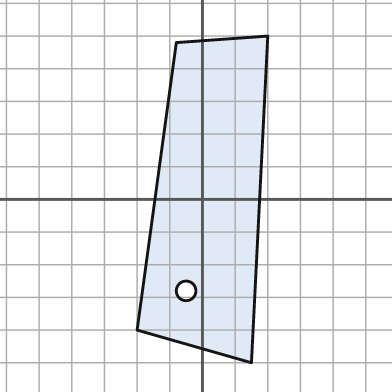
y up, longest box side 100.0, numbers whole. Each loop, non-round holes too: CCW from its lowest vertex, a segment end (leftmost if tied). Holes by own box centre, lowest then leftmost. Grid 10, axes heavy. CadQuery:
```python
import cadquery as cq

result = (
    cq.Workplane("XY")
    .moveTo(15.0, -50.0)
    .lineTo(20.0, 50.0)
    .lineTo(-8.0, 48.0)
    .lineTo(-20.0, -40.0)
    .close()
    .moveTo(-5.0, -28.0)
    .circle(3.0)
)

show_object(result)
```